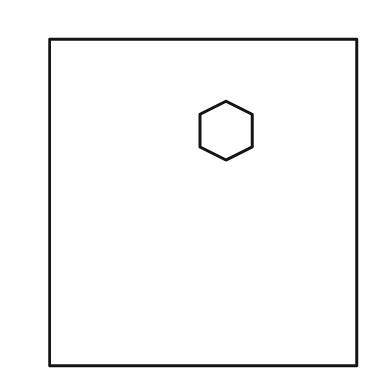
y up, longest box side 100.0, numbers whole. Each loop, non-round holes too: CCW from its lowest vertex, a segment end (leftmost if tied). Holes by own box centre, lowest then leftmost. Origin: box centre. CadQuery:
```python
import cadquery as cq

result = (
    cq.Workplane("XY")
    .moveTo(-47.0, -50.0)
    .lineTo(47.0, -50.0)
    .lineTo(47.0, 50.0)
    .lineTo(-47.0, 50.0)
    .close()
    .moveTo(7.0, 13.0)
    .lineTo(15.0, 17.0)
    .lineTo(15.0, 27.0)
    .lineTo(7.0, 31.0)
    .lineTo(-1.0, 27.0)
    .lineTo(-1.0, 17.0)
    .close()
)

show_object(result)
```